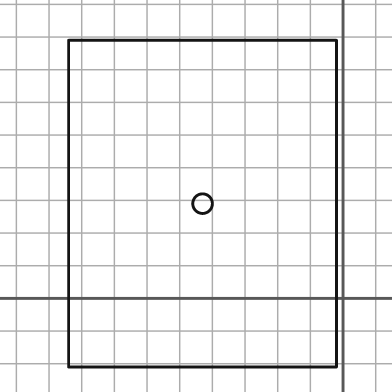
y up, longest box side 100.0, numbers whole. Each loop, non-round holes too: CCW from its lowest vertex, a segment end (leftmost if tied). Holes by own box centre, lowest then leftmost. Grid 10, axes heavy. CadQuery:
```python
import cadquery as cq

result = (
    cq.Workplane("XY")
    .moveTo(-84.0, -21.0)
    .lineTo(-2.0, -21.0)
    .lineTo(-2.0, 79.0)
    .lineTo(-84.0, 79.0)
    .close()
    .moveTo(-43.0, 29.0)
    .circle(3.0)
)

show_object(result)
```